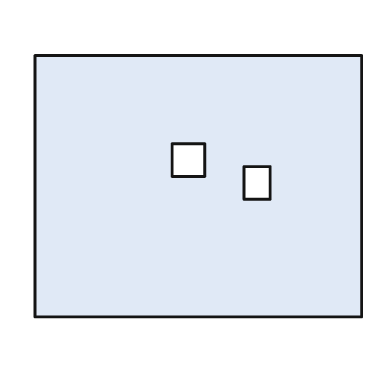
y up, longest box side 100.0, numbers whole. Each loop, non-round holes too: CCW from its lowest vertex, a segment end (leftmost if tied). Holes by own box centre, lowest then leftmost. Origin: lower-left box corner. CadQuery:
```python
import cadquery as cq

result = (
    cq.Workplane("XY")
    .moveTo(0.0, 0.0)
    .lineTo(100.0, 0.0)
    .lineTo(100.0, 80.0)
    .lineTo(0.0, 80.0)
    .close()
    .moveTo(64.0, 36.0)
    .lineTo(72.0, 36.0)
    .lineTo(72.0, 46.0)
    .lineTo(64.0, 46.0)
    .close()
    .moveTo(42.0, 43.0)
    .lineTo(52.0, 43.0)
    .lineTo(52.0, 53.0)
    .lineTo(42.0, 53.0)
    .close()
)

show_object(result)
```